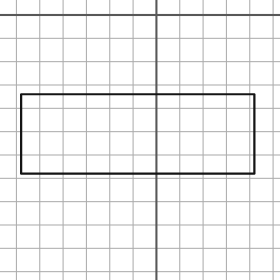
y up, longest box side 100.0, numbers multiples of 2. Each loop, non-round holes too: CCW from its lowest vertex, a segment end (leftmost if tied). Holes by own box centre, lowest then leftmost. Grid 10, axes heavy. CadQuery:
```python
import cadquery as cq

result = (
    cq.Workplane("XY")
    .moveTo(-58.0, -68.0)
    .lineTo(42.0, -68.0)
    .lineTo(42.0, -34.0)
    .lineTo(-58.0, -34.0)
    .close()
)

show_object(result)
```